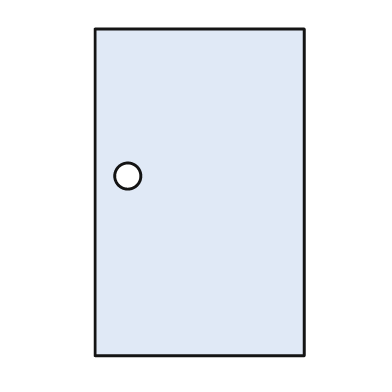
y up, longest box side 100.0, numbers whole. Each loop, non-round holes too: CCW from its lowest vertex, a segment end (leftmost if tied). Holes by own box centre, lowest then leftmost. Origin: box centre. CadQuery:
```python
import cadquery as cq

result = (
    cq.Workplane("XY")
    .moveTo(-32.0, -50.0)
    .lineTo(32.0, -50.0)
    .lineTo(32.0, 50.0)
    .lineTo(-32.0, 50.0)
    .close()
    .moveTo(-22.0, 5.0)
    .circle(4.0)
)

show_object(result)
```